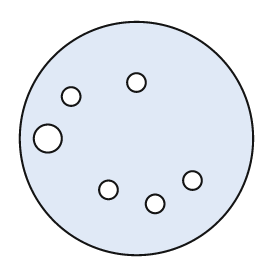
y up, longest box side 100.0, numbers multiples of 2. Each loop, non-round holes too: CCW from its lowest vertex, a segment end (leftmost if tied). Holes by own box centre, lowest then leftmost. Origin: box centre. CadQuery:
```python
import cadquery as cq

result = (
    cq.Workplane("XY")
    .moveTo(0.0, 0.0)
    .circle(50.0)
    .moveTo(8.0, -28.0)
    .circle(4.0)
    .moveTo(-12.0, -22.0)
    .circle(4.0)
    .moveTo(24.0, -18.0)
    .circle(4.0)
    .moveTo(-38.0, 0.0)
    .circle(6.0)
    .moveTo(-28.0, 18.0)
    .circle(4.0)
    .moveTo(0.0, 24.0)
    .circle(4.0)
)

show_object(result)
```